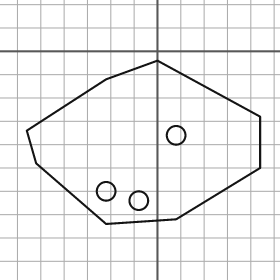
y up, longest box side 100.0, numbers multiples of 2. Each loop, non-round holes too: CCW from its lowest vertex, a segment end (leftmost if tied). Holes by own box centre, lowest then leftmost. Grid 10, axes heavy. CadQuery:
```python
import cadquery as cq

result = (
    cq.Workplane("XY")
    .moveTo(-22.0, -74.0)
    .lineTo(8.0, -72.0)
    .lineTo(44.0, -50.0)
    .lineTo(44.0, -28.0)
    .lineTo(0.0, -4.0)
    .lineTo(-22.0, -12.0)
    .lineTo(-56.0, -34.0)
    .lineTo(-52.0, -48.0)
    .close()
    .moveTo(-8.0, -64.0)
    .circle(4.0)
    .moveTo(-22.0, -60.0)
    .circle(4.0)
    .moveTo(8.0, -36.0)
    .circle(4.0)
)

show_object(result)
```